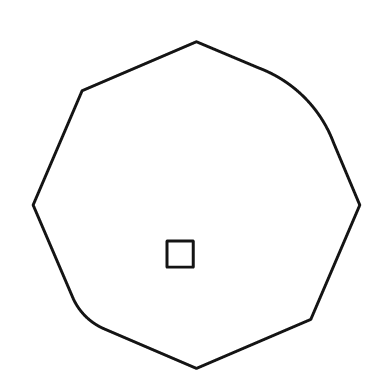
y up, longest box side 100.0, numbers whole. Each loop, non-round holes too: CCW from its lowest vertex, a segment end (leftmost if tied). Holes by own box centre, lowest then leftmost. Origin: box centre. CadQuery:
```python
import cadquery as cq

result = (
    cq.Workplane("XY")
    .moveTo(0.0, -50.0)
    .lineTo(35.0, -35.0)
    .lineTo(50.0, 0.0)
    .lineTo(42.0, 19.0)
    .threePointArc((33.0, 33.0), (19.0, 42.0))
    .lineTo(0.0, 50.0)
    .lineTo(-35.0, 35.0)
    .lineTo(-50.0, 0.0)
    .lineTo(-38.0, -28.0)
    .threePointArc((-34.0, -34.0), (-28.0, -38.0))
    .close()
    .moveTo(-9.0, -19.0)
    .lineTo(-1.0, -19.0)
    .lineTo(-1.0, -11.0)
    .lineTo(-9.0, -11.0)
    .close()
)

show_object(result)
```